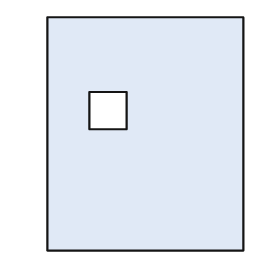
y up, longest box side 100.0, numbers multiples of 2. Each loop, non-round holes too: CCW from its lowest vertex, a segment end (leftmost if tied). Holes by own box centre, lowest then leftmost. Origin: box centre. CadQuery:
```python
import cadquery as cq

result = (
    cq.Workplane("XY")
    .moveTo(-42.0, -50.0)
    .lineTo(42.0, -50.0)
    .lineTo(42.0, 50.0)
    .lineTo(-42.0, 50.0)
    .close()
    .moveTo(-24.0, 2.0)
    .lineTo(-8.0, 2.0)
    .lineTo(-8.0, 18.0)
    .lineTo(-24.0, 18.0)
    .close()
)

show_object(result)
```